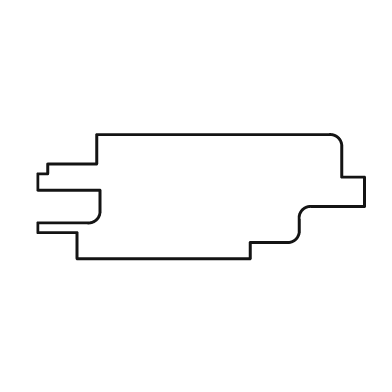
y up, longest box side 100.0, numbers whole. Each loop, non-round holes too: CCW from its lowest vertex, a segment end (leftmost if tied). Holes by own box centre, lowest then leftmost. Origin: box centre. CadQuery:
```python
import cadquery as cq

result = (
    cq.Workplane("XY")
    .moveTo(-38.0, -19.0)
    .lineTo(15.0, -19.0)
    .lineTo(15.0, -14.0)
    .lineTo(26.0, -14.0)
    .threePointArc((29.0, -13.0), (30.0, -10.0))
    .lineTo(30.0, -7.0)
    .threePointArc((31.0, -4.0), (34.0, -3.0))
    .lineTo(50.0, -3.0)
    .lineTo(50.0, 6.0)
    .lineTo(43.0, 6.0)
    .lineTo(43.0, 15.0)
    .threePointArc((42.0, 18.0), (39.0, 19.0))
    .lineTo(-32.0, 19.0)
    .lineTo(-32.0, 10.0)
    .lineTo(-47.0, 10.0)
    .lineTo(-47.0, 7.0)
    .lineTo(-50.0, 7.0)
    .lineTo(-50.0, 2.0)
    .lineTo(-31.0, 2.0)
    .lineTo(-31.0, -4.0)
    .threePointArc((-32.0, -7.0), (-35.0, -8.0))
    .lineTo(-50.0, -8.0)
    .lineTo(-50.0, -11.0)
    .lineTo(-38.0, -11.0)
    .close()
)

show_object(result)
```